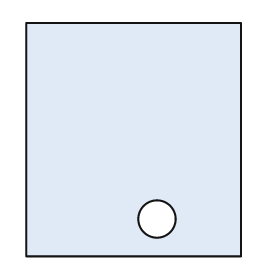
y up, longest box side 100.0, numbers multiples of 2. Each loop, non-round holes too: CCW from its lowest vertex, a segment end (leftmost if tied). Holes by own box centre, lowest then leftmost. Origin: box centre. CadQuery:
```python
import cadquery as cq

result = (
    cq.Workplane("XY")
    .moveTo(-46.0, -50.0)
    .lineTo(46.0, -50.0)
    .lineTo(46.0, 50.0)
    .lineTo(-46.0, 50.0)
    .close()
    .moveTo(10.0, -34.0)
    .circle(8.0)
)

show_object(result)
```